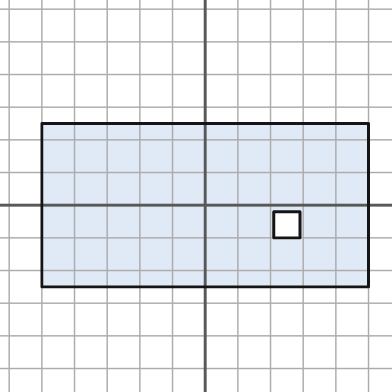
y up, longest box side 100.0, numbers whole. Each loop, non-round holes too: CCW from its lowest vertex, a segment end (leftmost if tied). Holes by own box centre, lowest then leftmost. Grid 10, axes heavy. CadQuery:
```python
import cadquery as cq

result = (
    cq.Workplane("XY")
    .moveTo(-50.0, -25.0)
    .lineTo(50.0, -25.0)
    .lineTo(50.0, 25.0)
    .lineTo(-50.0, 25.0)
    .close()
    .moveTo(21.0, -10.0)
    .lineTo(29.0, -10.0)
    .lineTo(29.0, -2.0)
    .lineTo(21.0, -2.0)
    .close()
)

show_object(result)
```